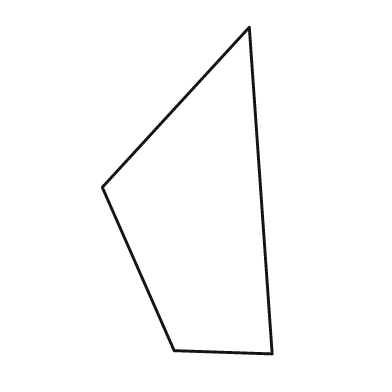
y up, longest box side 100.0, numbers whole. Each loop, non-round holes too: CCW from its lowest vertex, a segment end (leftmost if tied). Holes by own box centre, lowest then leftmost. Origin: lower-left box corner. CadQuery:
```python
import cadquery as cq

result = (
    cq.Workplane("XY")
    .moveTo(52.0, 0.0)
    .lineTo(45.0, 100.0)
    .lineTo(0.0, 51.0)
    .lineTo(22.0, 1.0)
    .close()
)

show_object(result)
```